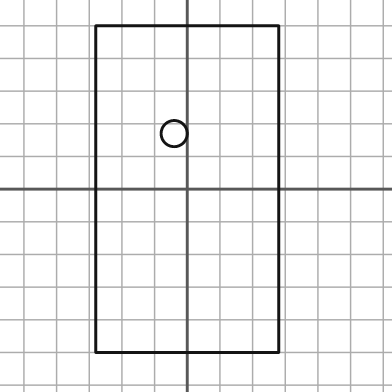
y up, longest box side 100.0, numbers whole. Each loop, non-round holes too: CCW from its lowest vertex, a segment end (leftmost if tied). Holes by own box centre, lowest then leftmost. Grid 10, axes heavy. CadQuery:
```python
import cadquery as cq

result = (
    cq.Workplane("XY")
    .moveTo(-28.0, -50.0)
    .lineTo(28.0, -50.0)
    .lineTo(28.0, 50.0)
    .lineTo(-28.0, 50.0)
    .close()
    .moveTo(-4.0, 17.0)
    .circle(4.0)
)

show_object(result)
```